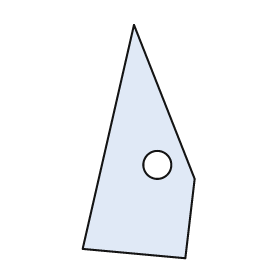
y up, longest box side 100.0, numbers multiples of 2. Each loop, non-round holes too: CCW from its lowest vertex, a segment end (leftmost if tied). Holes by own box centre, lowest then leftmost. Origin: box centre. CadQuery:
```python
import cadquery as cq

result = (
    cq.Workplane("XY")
    .moveTo(20.0, -50.0)
    .lineTo(24.0, -16.0)
    .lineTo(-2.0, 50.0)
    .lineTo(-24.0, -46.0)
    .close()
    .moveTo(8.0, -10.0)
    .circle(6.0)
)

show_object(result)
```